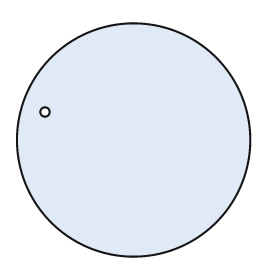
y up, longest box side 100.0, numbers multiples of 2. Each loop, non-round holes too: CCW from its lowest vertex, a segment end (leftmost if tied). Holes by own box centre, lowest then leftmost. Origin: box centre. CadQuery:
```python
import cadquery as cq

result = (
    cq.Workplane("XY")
    .moveTo(0.0, 0.0)
    .circle(50.0)
    .moveTo(-38.0, 12.0)
    .circle(2.0)
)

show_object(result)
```